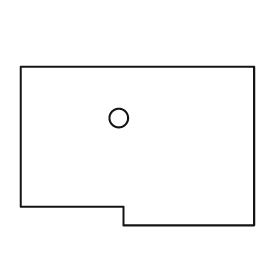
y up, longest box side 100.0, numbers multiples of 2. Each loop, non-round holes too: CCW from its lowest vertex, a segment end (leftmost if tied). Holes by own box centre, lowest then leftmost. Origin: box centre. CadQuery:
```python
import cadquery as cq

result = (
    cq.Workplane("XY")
    .moveTo(-6.0, -34.0)
    .lineTo(50.0, -34.0)
    .lineTo(50.0, 34.0)
    .lineTo(-50.0, 34.0)
    .lineTo(-50.0, -26.0)
    .lineTo(-6.0, -26.0)
    .close()
    .moveTo(-8.0, 12.0)
    .circle(4.0)
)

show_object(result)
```